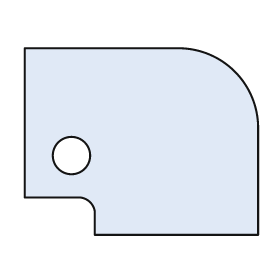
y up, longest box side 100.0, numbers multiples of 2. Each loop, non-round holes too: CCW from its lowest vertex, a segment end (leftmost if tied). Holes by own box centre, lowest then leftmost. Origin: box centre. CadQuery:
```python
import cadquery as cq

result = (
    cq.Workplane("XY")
    .moveTo(-20.0, -40.0)
    .lineTo(50.0, -40.0)
    .lineTo(50.0, 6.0)
    .threePointArc((40.0, 30.0), (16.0, 40.0))
    .lineTo(-50.0, 40.0)
    .lineTo(-50.0, -24.0)
    .lineTo(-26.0, -24.0)
    .threePointArc((-22.0, -26.0), (-20.0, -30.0))
    .close()
    .moveTo(-30.0, -6.0)
    .circle(8.0)
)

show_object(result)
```